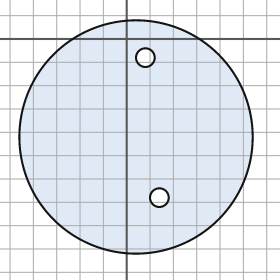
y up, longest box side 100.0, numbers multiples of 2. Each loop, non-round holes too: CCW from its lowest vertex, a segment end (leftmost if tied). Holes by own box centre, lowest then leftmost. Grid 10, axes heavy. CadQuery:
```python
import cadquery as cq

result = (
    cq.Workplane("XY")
    .moveTo(4.0, -42.0)
    .circle(50.0)
    .moveTo(14.0, -68.0)
    .circle(4.0)
    .moveTo(8.0, -8.0)
    .circle(4.0)
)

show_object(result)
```